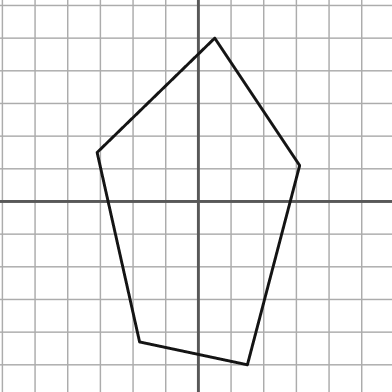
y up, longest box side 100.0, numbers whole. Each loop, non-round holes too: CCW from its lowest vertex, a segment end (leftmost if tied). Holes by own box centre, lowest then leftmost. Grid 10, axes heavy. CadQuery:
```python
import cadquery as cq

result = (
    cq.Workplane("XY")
    .moveTo(15.0, -50.0)
    .lineTo(31.0, 11.0)
    .lineTo(5.0, 50.0)
    .lineTo(-31.0, 15.0)
    .lineTo(-18.0, -43.0)
    .close()
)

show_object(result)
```